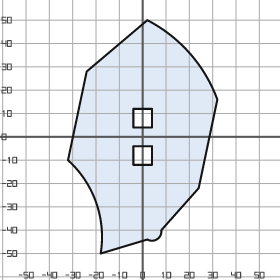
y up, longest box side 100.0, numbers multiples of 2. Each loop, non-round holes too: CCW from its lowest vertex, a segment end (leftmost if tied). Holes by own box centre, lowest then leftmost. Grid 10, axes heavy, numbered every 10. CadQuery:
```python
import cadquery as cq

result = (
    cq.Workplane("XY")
    .moveTo(-18.0, -50.0)
    .lineTo(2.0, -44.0)
    .threePointArc((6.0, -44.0), (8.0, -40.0))
    .lineTo(24.0, -22.0)
    .lineTo(32.0, 16.0)
    .threePointArc((20.0, 36.0), (2.0, 50.0))
    .lineTo(-24.0, 28.0)
    .lineTo(-32.0, -10.0)
    .threePointArc((-20.0, -28.0), (-18.0, -50.0))
    .close()
    .moveTo(-4.0, -12.0)
    .lineTo(4.0, -12.0)
    .lineTo(4.0, -4.0)
    .lineTo(-4.0, -4.0)
    .close()
    .moveTo(-4.0, 4.0)
    .lineTo(4.0, 4.0)
    .lineTo(4.0, 12.0)
    .lineTo(-4.0, 12.0)
    .close()
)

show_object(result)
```